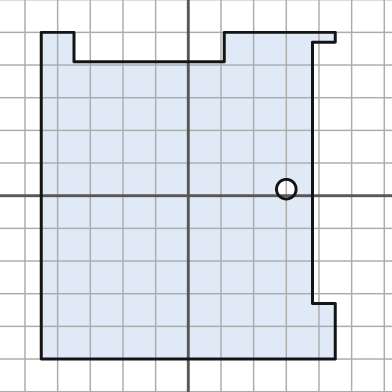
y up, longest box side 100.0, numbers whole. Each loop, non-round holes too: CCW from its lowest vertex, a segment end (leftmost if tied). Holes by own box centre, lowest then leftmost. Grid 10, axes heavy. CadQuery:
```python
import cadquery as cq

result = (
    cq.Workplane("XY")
    .moveTo(-45.0, -50.0)
    .lineTo(45.0, -50.0)
    .lineTo(45.0, -33.0)
    .lineTo(38.0, -33.0)
    .lineTo(38.0, 47.0)
    .lineTo(45.0, 47.0)
    .lineTo(45.0, 50.0)
    .lineTo(11.0, 50.0)
    .lineTo(11.0, 41.0)
    .lineTo(-35.0, 41.0)
    .lineTo(-35.0, 50.0)
    .lineTo(-45.0, 50.0)
    .close()
    .moveTo(30.0, 2.0)
    .circle(3.0)
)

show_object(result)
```